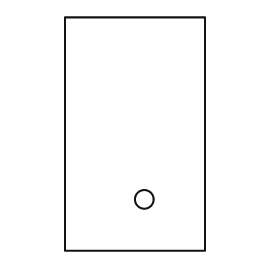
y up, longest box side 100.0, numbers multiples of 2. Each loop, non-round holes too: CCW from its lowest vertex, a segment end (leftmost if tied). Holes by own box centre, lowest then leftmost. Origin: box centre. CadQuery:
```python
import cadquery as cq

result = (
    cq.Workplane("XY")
    .moveTo(-30.0, -50.0)
    .lineTo(30.0, -50.0)
    .lineTo(30.0, 50.0)
    .lineTo(-30.0, 50.0)
    .close()
    .moveTo(4.0, -28.0)
    .circle(4.0)
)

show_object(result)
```